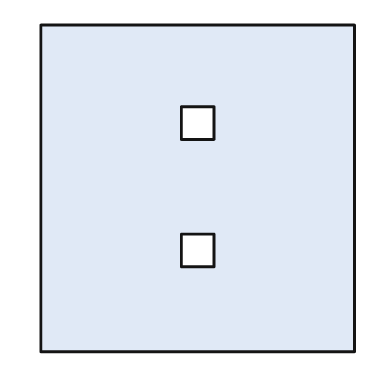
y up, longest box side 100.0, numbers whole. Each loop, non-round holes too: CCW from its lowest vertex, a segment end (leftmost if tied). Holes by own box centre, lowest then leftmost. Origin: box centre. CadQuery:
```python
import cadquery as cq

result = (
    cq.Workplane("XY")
    .moveTo(-48.0, -50.0)
    .lineTo(48.0, -50.0)
    .lineTo(48.0, 50.0)
    .lineTo(-48.0, 50.0)
    .close()
    .moveTo(-5.0, -24.0)
    .lineTo(5.0, -24.0)
    .lineTo(5.0, -14.0)
    .lineTo(-5.0, -14.0)
    .close()
    .moveTo(-5.0, 15.0)
    .lineTo(5.0, 15.0)
    .lineTo(5.0, 25.0)
    .lineTo(-5.0, 25.0)
    .close()
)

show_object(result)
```